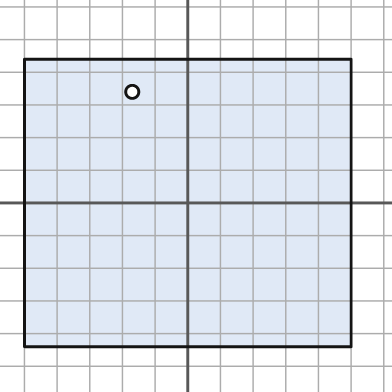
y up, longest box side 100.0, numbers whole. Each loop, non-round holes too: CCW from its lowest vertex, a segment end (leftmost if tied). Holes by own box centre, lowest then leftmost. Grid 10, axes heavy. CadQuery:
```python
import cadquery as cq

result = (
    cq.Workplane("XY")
    .moveTo(-50.0, -44.0)
    .lineTo(50.0, -44.0)
    .lineTo(50.0, 44.0)
    .lineTo(-50.0, 44.0)
    .close()
    .moveTo(-17.0, 34.0)
    .circle(2.0)
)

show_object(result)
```